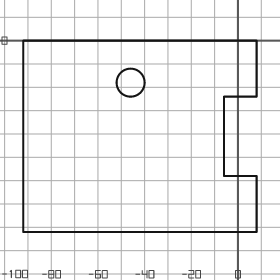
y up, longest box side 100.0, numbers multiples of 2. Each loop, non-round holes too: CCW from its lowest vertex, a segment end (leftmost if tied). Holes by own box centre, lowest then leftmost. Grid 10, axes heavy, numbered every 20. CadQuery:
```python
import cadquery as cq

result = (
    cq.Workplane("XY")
    .moveTo(-92.0, -82.0)
    .lineTo(8.0, -82.0)
    .lineTo(8.0, -58.0)
    .lineTo(-6.0, -58.0)
    .lineTo(-6.0, -24.0)
    .lineTo(8.0, -24.0)
    .lineTo(8.0, 0.0)
    .lineTo(-92.0, 0.0)
    .close()
    .moveTo(-46.0, -18.0)
    .circle(6.0)
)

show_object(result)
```